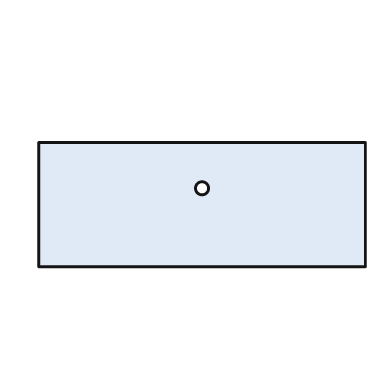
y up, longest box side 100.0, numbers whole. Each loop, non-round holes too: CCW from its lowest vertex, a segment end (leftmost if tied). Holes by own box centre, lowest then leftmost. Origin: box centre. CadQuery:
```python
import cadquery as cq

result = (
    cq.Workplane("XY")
    .moveTo(-50.0, -19.0)
    .lineTo(50.0, -19.0)
    .lineTo(50.0, 19.0)
    .lineTo(-50.0, 19.0)
    .close()
    .moveTo(0.0, 5.0)
    .circle(2.0)
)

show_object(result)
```